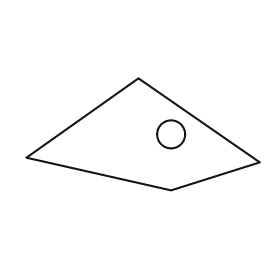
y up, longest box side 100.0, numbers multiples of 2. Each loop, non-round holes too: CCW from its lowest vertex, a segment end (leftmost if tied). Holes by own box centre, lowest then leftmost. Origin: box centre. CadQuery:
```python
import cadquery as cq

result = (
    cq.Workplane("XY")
    .moveTo(12.0, -24.0)
    .lineTo(50.0, -12.0)
    .lineTo(-2.0, 24.0)
    .lineTo(-50.0, -10.0)
    .close()
    .moveTo(12.0, 0.0)
    .circle(6.0)
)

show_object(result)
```